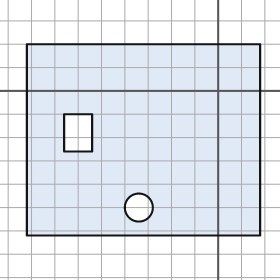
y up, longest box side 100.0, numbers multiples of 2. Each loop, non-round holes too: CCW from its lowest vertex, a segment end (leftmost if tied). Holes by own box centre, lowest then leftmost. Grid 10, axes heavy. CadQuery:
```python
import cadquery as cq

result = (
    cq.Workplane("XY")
    .moveTo(-82.0, -62.0)
    .lineTo(18.0, -62.0)
    .lineTo(18.0, 20.0)
    .lineTo(-82.0, 20.0)
    .close()
    .moveTo(-34.0, -50.0)
    .circle(6.0)
    .moveTo(-66.0, -26.0)
    .lineTo(-54.0, -26.0)
    .lineTo(-54.0, -10.0)
    .lineTo(-66.0, -10.0)
    .close()
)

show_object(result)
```